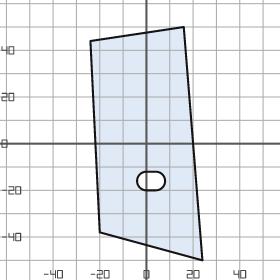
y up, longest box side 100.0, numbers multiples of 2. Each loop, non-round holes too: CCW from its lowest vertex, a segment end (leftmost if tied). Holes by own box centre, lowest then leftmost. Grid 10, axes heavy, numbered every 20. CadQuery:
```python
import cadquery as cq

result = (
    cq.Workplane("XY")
    .moveTo(24.0, -50.0)
    .lineTo(16.0, 50.0)
    .lineTo(-24.0, 44.0)
    .lineTo(-20.0, -38.0)
    .close()
    .moveTo(0.0, -20.0)
    .lineTo(4.0, -20.0)
    .threePointArc((8.0, -16.0), (4.0, -12.0))
    .lineTo(0.0, -12.0)
    .threePointArc((-4.0, -16.0), (0.0, -20.0))
    .close()
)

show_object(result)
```